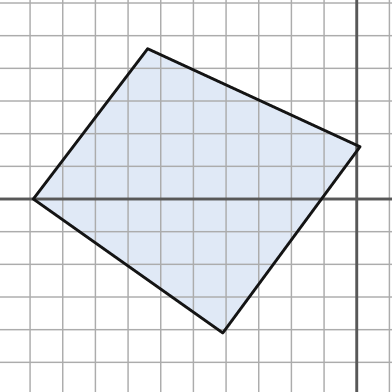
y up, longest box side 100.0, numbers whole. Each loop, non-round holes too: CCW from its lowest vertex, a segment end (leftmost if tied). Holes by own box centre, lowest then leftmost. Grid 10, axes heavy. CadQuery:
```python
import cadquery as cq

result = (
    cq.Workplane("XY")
    .moveTo(-41.0, -41.0)
    .lineTo(1.0, 16.0)
    .lineTo(-64.0, 46.0)
    .lineTo(-99.0, 0.0)
    .close()
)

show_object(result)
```